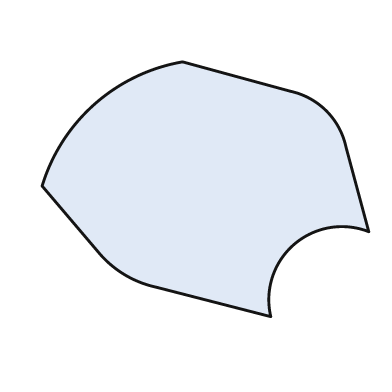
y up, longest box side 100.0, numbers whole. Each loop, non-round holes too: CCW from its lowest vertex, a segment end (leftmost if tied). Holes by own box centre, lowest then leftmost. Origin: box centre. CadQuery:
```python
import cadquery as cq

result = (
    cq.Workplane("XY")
    .moveTo(20.0, -39.0)
    .threePointArc((27.0, -17.0), (50.0, -13.0))
    .lineTo(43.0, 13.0)
    .threePointArc((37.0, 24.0), (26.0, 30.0))
    .lineTo(-7.0, 39.0)
    .threePointArc((-34.0, 26.0), (-50.0, 1.0))
    .lineTo(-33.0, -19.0)
    .threePointArc((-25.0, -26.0), (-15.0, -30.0))
    .close()
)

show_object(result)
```